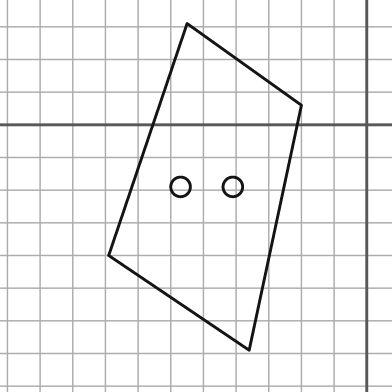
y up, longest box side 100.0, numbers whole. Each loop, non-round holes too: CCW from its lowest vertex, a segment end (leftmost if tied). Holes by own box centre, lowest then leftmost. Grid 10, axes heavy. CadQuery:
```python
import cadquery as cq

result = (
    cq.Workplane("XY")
    .moveTo(-36.0, -69.0)
    .lineTo(-20.0, 6.0)
    .lineTo(-55.0, 31.0)
    .lineTo(-79.0, -40.0)
    .close()
    .moveTo(-57.0, -19.0)
    .circle(3.0)
    .moveTo(-41.0, -19.0)
    .circle(3.0)
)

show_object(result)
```